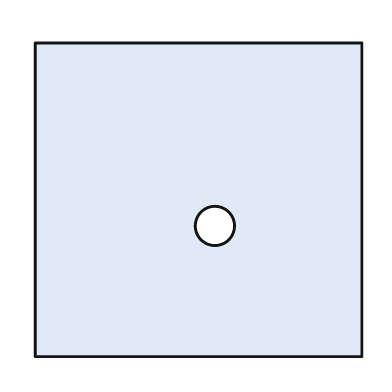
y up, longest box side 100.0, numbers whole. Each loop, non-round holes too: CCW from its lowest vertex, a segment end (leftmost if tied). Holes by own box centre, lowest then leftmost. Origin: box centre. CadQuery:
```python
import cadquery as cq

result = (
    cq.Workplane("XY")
    .moveTo(-50.0, -48.0)
    .lineTo(50.0, -48.0)
    .lineTo(50.0, 48.0)
    .lineTo(-50.0, 48.0)
    .close()
    .moveTo(5.0, -8.0)
    .circle(6.0)
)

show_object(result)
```